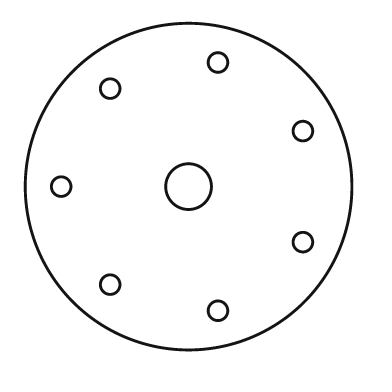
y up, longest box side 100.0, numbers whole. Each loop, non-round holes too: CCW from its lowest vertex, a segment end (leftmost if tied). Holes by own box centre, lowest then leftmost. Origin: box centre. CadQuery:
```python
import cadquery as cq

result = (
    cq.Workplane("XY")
    .moveTo(0.0, 0.0)
    .circle(50.0)
    .moveTo(9.0, -38.0)
    .circle(3.0)
    .moveTo(-24.0, -30.0)
    .circle(3.0)
    .moveTo(35.0, -17.0)
    .circle(3.0)
    .moveTo(-39.0, 0.0)
    .circle(3.0)
    .moveTo(0.0, 0.0)
    .circle(7.0)
    .moveTo(35.0, 17.0)
    .circle(3.0)
    .moveTo(-24.0, 30.0)
    .circle(3.0)
    .moveTo(9.0, 38.0)
    .circle(3.0)
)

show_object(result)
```